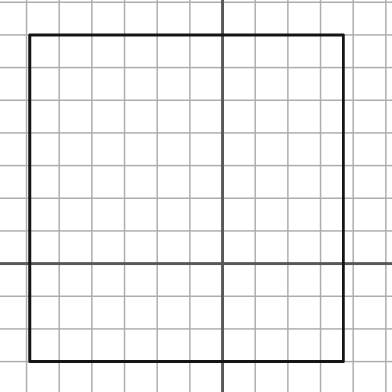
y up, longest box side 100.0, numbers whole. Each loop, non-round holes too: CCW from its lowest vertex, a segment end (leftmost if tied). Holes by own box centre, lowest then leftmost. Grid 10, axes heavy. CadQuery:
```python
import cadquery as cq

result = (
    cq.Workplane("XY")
    .moveTo(-59.0, -30.0)
    .lineTo(37.0, -30.0)
    .lineTo(37.0, 70.0)
    .lineTo(-59.0, 70.0)
    .close()
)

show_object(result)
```